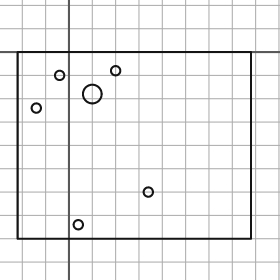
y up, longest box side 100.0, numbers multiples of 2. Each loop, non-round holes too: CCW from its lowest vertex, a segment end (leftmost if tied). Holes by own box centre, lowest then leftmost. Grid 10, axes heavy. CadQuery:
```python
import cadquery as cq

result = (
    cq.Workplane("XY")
    .moveTo(-22.0, -80.0)
    .lineTo(78.0, -80.0)
    .lineTo(78.0, 0.0)
    .lineTo(-22.0, 0.0)
    .close()
    .moveTo(4.0, -74.0)
    .circle(2.0)
    .moveTo(34.0, -60.0)
    .circle(2.0)
    .moveTo(-14.0, -24.0)
    .circle(2.0)
    .moveTo(10.0, -18.0)
    .circle(4.0)
    .moveTo(-4.0, -10.0)
    .circle(2.0)
    .moveTo(20.0, -8.0)
    .circle(2.0)
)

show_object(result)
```